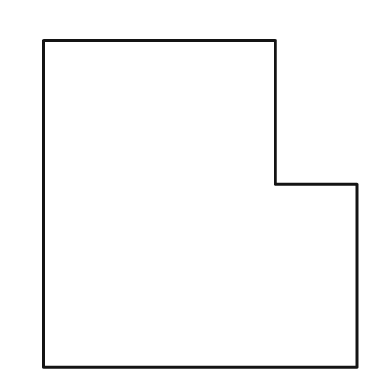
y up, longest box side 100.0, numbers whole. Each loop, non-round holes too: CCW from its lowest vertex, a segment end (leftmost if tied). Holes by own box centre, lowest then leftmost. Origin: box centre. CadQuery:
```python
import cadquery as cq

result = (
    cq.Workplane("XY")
    .moveTo(-48.0, -50.0)
    .lineTo(48.0, -50.0)
    .lineTo(48.0, 6.0)
    .lineTo(23.0, 6.0)
    .lineTo(23.0, 50.0)
    .lineTo(-48.0, 50.0)
    .close()
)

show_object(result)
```